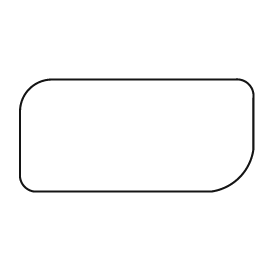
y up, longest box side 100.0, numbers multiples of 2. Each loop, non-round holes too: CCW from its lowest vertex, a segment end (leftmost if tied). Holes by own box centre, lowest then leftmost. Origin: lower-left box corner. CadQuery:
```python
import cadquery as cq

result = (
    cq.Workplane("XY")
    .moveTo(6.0, 0.0)
    .lineTo(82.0, 0.0)
    .threePointArc((94.0, 6.0), (100.0, 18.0))
    .lineTo(100.0, 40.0)
    .threePointArc((98.0, 46.0), (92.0, 48.0))
    .lineTo(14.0, 48.0)
    .threePointArc((4.0, 44.0), (0.0, 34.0))
    .lineTo(0.0, 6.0)
    .threePointArc((2.0, 2.0), (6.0, 0.0))
    .close()
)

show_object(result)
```